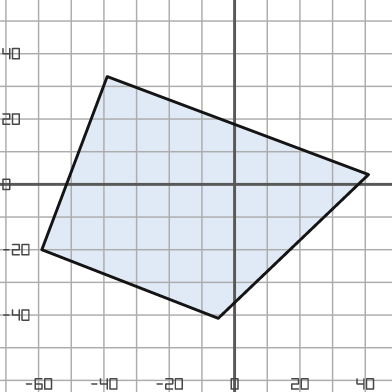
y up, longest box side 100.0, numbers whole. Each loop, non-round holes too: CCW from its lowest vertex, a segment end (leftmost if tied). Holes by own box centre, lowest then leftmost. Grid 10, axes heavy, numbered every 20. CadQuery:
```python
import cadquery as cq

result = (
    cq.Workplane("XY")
    .moveTo(-5.0, -41.0)
    .lineTo(41.0, 3.0)
    .lineTo(-39.0, 33.0)
    .lineTo(-59.0, -20.0)
    .close()
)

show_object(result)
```